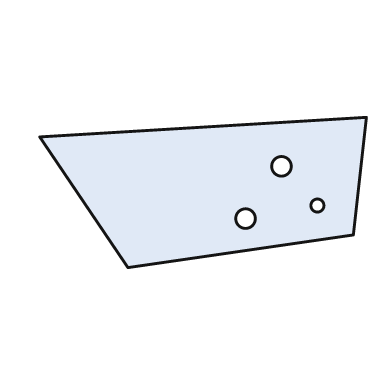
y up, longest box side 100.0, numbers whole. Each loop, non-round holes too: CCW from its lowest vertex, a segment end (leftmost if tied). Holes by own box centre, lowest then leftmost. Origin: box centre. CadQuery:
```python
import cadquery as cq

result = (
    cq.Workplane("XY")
    .moveTo(-23.0, -23.0)
    .lineTo(46.0, -13.0)
    .lineTo(50.0, 23.0)
    .lineTo(-50.0, 17.0)
    .close()
    .moveTo(13.0, -8.0)
    .circle(3.0)
    .moveTo(35.0, -4.0)
    .circle(2.0)
    .moveTo(24.0, 8.0)
    .circle(3.0)
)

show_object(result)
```